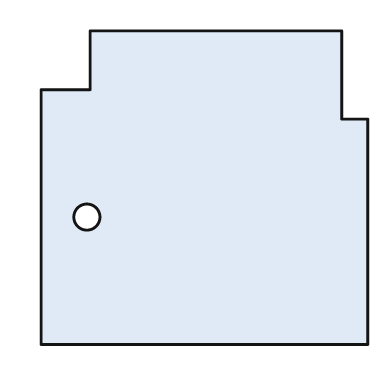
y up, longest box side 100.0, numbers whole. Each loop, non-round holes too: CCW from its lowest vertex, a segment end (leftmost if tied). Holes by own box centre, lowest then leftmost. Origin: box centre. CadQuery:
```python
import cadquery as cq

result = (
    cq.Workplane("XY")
    .moveTo(-50.0, -48.0)
    .lineTo(50.0, -48.0)
    .lineTo(50.0, 21.0)
    .lineTo(42.0, 21.0)
    .lineTo(42.0, 48.0)
    .lineTo(-35.0, 48.0)
    .lineTo(-35.0, 30.0)
    .lineTo(-50.0, 30.0)
    .close()
    .moveTo(-36.0, -9.0)
    .circle(4.0)
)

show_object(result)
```